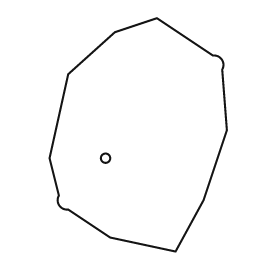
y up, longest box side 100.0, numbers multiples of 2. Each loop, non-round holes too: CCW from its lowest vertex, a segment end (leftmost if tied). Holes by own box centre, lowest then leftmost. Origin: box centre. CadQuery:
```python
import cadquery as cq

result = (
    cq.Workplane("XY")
    .moveTo(16.0, -50.0)
    .lineTo(28.0, -28.0)
    .lineTo(38.0, 2.0)
    .lineTo(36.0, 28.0)
    .threePointArc((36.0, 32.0), (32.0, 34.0))
    .lineTo(8.0, 50.0)
    .lineTo(-10.0, 44.0)
    .lineTo(-30.0, 26.0)
    .lineTo(-38.0, -10.0)
    .lineTo(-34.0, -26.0)
    .threePointArc((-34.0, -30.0), (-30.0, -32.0))
    .lineTo(-12.0, -44.0)
    .close()
    .moveTo(-14.0, -10.0)
    .circle(2.0)
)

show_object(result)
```